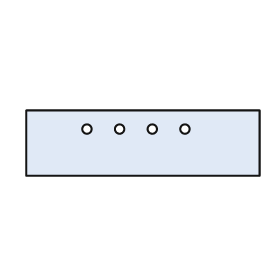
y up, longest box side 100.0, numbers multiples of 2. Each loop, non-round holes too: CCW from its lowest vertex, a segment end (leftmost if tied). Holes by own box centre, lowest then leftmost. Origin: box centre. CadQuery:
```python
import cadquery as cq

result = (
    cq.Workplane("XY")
    .moveTo(-50.0, -14.0)
    .lineTo(50.0, -14.0)
    .lineTo(50.0, 14.0)
    .lineTo(-50.0, 14.0)
    .close()
    .moveTo(-24.0, 6.0)
    .circle(2.0)
    .moveTo(-10.0, 6.0)
    .circle(2.0)
    .moveTo(4.0, 6.0)
    .circle(2.0)
    .moveTo(18.0, 6.0)
    .circle(2.0)
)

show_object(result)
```